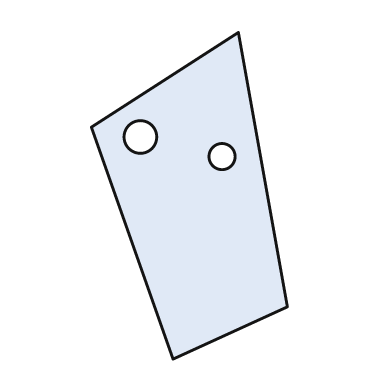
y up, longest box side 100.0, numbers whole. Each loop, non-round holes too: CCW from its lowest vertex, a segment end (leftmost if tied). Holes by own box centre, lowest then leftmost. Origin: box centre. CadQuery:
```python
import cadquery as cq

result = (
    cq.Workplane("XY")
    .moveTo(-5.0, -50.0)
    .lineTo(30.0, -34.0)
    .lineTo(15.0, 50.0)
    .lineTo(-30.0, 21.0)
    .close()
    .moveTo(10.0, 12.0)
    .circle(4.0)
    .moveTo(-15.0, 18.0)
    .circle(5.0)
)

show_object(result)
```